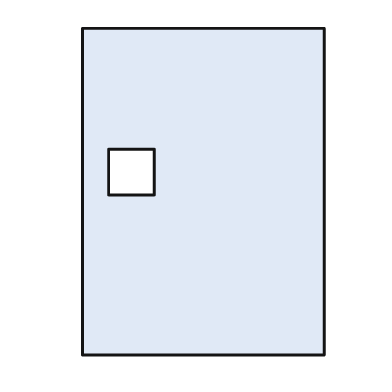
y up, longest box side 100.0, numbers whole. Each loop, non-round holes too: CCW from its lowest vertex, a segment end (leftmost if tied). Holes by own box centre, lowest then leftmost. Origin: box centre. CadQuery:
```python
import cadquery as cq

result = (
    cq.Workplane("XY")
    .moveTo(-37.0, -50.0)
    .lineTo(37.0, -50.0)
    .lineTo(37.0, 50.0)
    .lineTo(-37.0, 50.0)
    .close()
    .moveTo(-29.0, -1.0)
    .lineTo(-15.0, -1.0)
    .lineTo(-15.0, 13.0)
    .lineTo(-29.0, 13.0)
    .close()
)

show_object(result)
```